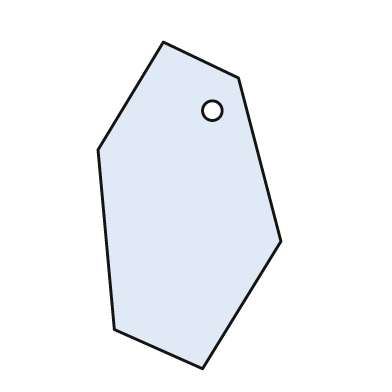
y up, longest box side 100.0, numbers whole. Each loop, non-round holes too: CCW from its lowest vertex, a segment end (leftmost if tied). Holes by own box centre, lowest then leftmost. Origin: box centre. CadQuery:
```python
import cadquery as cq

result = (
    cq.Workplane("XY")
    .moveTo(4.0, -50.0)
    .lineTo(28.0, -11.0)
    .lineTo(15.0, 39.0)
    .lineTo(-8.0, 50.0)
    .lineTo(-28.0, 17.0)
    .lineTo(-23.0, -38.0)
    .close()
    .moveTo(7.0, 29.0)
    .circle(3.0)
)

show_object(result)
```